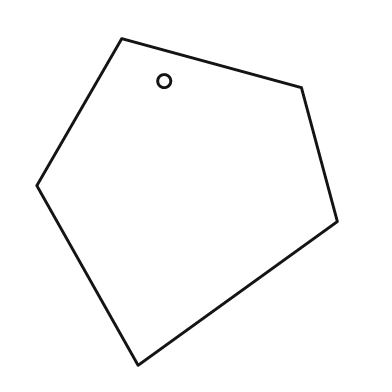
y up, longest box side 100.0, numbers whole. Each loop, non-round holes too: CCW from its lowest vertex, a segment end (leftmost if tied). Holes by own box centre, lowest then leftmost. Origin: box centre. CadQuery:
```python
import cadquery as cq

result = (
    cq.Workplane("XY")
    .moveTo(-15.0, -50.0)
    .lineTo(46.0, -6.0)
    .lineTo(35.0, 35.0)
    .lineTo(-20.0, 50.0)
    .lineTo(-46.0, 5.0)
    .close()
    .moveTo(-7.0, 37.0)
    .circle(2.0)
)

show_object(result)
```